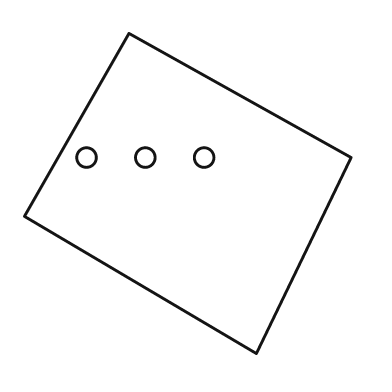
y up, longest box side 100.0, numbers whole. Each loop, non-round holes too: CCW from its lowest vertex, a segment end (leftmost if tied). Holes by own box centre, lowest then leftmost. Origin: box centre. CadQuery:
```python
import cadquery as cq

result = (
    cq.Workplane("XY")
    .moveTo(21.0, -49.0)
    .lineTo(50.0, 11.0)
    .lineTo(-18.0, 49.0)
    .lineTo(-50.0, -7.0)
    .close()
    .moveTo(-31.0, 11.0)
    .circle(3.0)
    .moveTo(-13.0, 11.0)
    .circle(3.0)
    .moveTo(5.0, 11.0)
    .circle(3.0)
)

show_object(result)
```